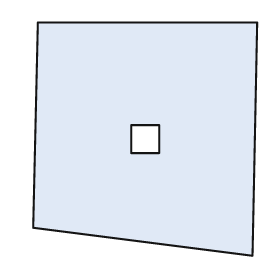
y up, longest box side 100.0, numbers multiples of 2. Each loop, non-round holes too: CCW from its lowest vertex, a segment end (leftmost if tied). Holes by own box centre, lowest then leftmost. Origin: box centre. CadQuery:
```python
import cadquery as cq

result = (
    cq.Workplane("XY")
    .moveTo(46.0, -50.0)
    .lineTo(48.0, 50.0)
    .lineTo(-46.0, 50.0)
    .lineTo(-48.0, -38.0)
    .close()
    .moveTo(-6.0, -6.0)
    .lineTo(6.0, -6.0)
    .lineTo(6.0, 6.0)
    .lineTo(-6.0, 6.0)
    .close()
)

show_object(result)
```